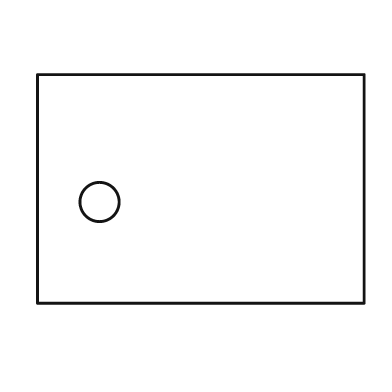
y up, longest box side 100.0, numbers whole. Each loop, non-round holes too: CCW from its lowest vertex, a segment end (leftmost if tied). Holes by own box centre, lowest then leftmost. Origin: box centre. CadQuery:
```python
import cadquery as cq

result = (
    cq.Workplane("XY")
    .moveTo(-50.0, -35.0)
    .lineTo(50.0, -35.0)
    .lineTo(50.0, 35.0)
    .lineTo(-50.0, 35.0)
    .close()
    .moveTo(-31.0, -4.0)
    .circle(6.0)
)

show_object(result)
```